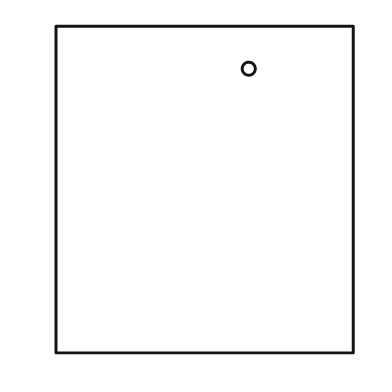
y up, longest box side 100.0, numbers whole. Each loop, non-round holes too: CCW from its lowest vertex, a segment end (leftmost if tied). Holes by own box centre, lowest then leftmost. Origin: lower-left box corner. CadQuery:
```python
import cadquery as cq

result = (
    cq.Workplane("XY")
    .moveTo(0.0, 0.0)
    .lineTo(91.0, 0.0)
    .lineTo(91.0, 100.0)
    .lineTo(0.0, 100.0)
    .close()
    .moveTo(59.0, 87.0)
    .circle(2.0)
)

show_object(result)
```